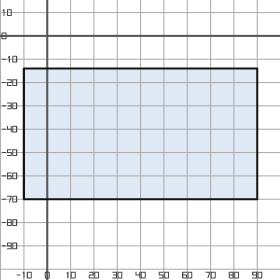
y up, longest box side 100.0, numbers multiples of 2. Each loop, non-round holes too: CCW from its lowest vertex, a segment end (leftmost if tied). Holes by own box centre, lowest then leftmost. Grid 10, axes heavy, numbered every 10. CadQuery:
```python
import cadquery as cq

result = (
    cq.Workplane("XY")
    .moveTo(-10.0, -70.0)
    .lineTo(90.0, -70.0)
    .lineTo(90.0, -14.0)
    .lineTo(-10.0, -14.0)
    .close()
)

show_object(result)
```